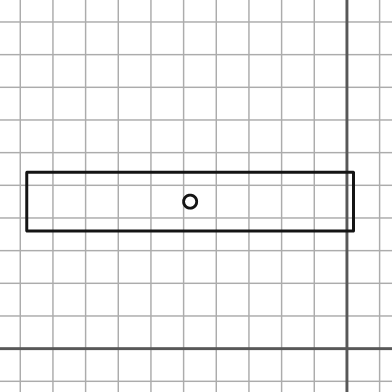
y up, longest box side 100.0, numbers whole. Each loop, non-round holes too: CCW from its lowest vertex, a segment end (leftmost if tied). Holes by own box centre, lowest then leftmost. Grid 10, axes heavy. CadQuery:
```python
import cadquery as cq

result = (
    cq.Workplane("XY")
    .moveTo(-98.0, 36.0)
    .lineTo(2.0, 36.0)
    .lineTo(2.0, 54.0)
    .lineTo(-98.0, 54.0)
    .close()
    .moveTo(-48.0, 45.0)
    .circle(2.0)
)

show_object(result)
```